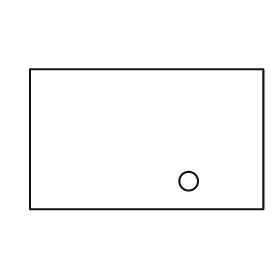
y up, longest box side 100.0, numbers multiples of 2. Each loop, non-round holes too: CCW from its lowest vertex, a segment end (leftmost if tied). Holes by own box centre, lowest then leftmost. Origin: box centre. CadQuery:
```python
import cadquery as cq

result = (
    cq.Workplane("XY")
    .moveTo(-50.0, -30.0)
    .lineTo(50.0, -30.0)
    .lineTo(50.0, 30.0)
    .lineTo(-50.0, 30.0)
    .close()
    .moveTo(18.0, -18.0)
    .circle(4.0)
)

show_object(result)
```